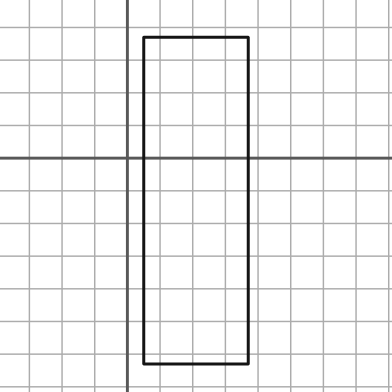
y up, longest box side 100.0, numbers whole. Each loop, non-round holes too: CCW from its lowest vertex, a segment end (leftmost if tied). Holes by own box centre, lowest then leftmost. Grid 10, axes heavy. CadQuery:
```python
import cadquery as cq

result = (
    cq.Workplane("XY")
    .moveTo(5.0, -63.0)
    .lineTo(37.0, -63.0)
    .lineTo(37.0, 37.0)
    .lineTo(5.0, 37.0)
    .close()
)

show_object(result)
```